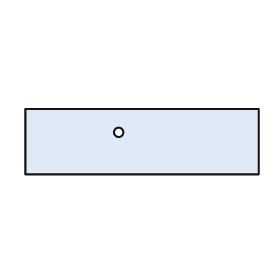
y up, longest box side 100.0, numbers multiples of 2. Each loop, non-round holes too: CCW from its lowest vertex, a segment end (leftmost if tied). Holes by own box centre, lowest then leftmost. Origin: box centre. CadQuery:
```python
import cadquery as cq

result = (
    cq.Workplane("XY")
    .moveTo(-50.0, -14.0)
    .lineTo(50.0, -14.0)
    .lineTo(50.0, 14.0)
    .lineTo(-50.0, 14.0)
    .close()
    .moveTo(-10.0, 4.0)
    .circle(2.0)
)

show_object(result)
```